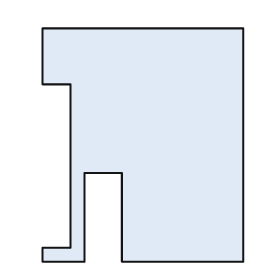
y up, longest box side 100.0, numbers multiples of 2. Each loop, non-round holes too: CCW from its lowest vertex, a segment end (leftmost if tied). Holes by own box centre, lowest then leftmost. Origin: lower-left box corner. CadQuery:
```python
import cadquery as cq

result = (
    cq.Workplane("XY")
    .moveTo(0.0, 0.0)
    .lineTo(18.0, 0.0)
    .lineTo(18.0, 38.0)
    .lineTo(34.0, 38.0)
    .lineTo(34.0, 0.0)
    .lineTo(86.0, 0.0)
    .lineTo(86.0, 100.0)
    .lineTo(0.0, 100.0)
    .lineTo(0.0, 76.0)
    .lineTo(12.0, 76.0)
    .lineTo(12.0, 6.0)
    .lineTo(0.0, 6.0)
    .close()
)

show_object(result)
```